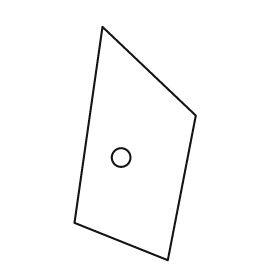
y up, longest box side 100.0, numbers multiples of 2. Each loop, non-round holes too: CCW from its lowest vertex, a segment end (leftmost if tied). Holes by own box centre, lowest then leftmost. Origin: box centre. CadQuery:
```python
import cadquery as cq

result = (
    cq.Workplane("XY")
    .moveTo(14.0, -50.0)
    .lineTo(26.0, 12.0)
    .lineTo(-14.0, 50.0)
    .lineTo(-26.0, -34.0)
    .close()
    .moveTo(-6.0, -6.0)
    .circle(4.0)
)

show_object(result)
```